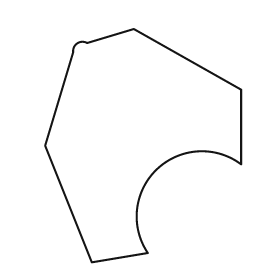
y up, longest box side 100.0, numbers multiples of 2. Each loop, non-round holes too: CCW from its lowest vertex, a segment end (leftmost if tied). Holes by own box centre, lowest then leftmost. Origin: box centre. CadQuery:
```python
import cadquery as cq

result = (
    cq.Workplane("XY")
    .moveTo(-22.0, -50.0)
    .lineTo(2.0, -46.0)
    .threePointArc((6.0, -10.0), (42.0, -8.0))
    .lineTo(42.0, 24.0)
    .lineTo(-4.0, 50.0)
    .lineTo(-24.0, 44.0)
    .threePointArc((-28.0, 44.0), (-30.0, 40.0))
    .lineTo(-42.0, 0.0)
    .close()
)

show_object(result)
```